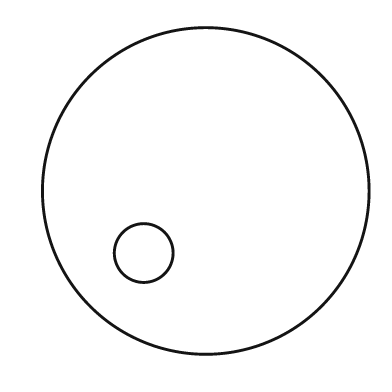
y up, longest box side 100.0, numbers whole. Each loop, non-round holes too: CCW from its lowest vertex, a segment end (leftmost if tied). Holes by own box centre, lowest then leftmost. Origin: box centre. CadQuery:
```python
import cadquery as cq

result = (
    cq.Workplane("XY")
    .moveTo(0.0, 0.0)
    .circle(50.0)
    .moveTo(-19.0, -19.0)
    .circle(9.0)
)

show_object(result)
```